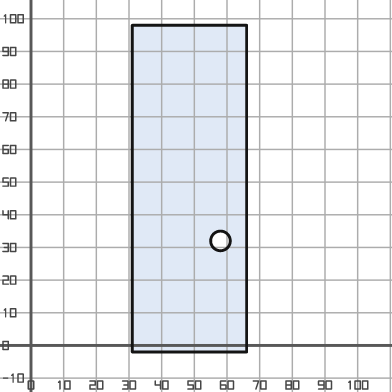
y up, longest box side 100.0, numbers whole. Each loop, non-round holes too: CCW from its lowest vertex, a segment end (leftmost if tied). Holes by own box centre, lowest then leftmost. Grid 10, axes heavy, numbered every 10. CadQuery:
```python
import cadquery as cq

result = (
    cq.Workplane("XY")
    .moveTo(31.0, -2.0)
    .lineTo(66.0, -2.0)
    .lineTo(66.0, 98.0)
    .lineTo(31.0, 98.0)
    .close()
    .moveTo(58.0, 32.0)
    .circle(3.0)
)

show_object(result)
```